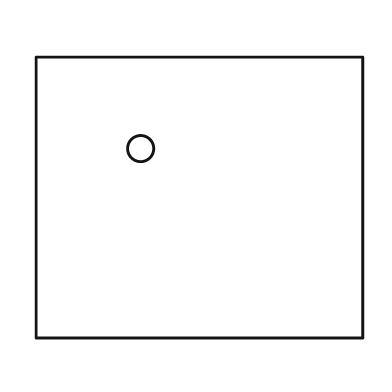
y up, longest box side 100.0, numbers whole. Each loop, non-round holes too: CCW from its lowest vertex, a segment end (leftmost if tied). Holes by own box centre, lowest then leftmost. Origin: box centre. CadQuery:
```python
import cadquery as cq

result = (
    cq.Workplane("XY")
    .moveTo(-50.0, -43.0)
    .lineTo(50.0, -43.0)
    .lineTo(50.0, 43.0)
    .lineTo(-50.0, 43.0)
    .close()
    .moveTo(-18.0, 15.0)
    .circle(4.0)
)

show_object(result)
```